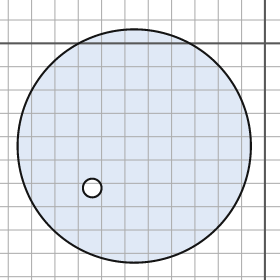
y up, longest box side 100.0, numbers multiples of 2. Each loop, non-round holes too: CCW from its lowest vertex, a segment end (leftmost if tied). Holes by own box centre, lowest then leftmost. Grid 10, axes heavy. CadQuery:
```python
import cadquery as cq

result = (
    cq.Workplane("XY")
    .moveTo(-56.0, -44.0)
    .circle(50.0)
    .moveTo(-74.0, -62.0)
    .circle(4.0)
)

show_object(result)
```